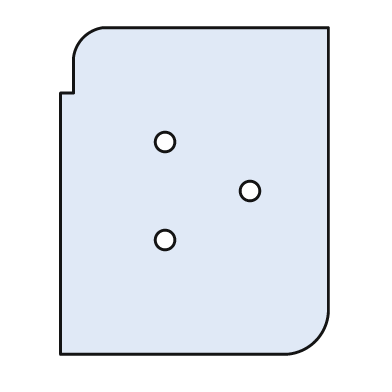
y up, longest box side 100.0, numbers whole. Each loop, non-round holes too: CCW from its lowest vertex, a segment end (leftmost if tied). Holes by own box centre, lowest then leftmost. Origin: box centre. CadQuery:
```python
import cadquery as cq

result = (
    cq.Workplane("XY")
    .moveTo(-41.0, -50.0)
    .lineTo(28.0, -50.0)
    .threePointArc((37.0, -46.0), (41.0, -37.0))
    .lineTo(41.0, 50.0)
    .lineTo(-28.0, 50.0)
    .threePointArc((-34.0, 47.0), (-37.0, 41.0))
    .lineTo(-37.0, 30.0)
    .lineTo(-41.0, 30.0)
    .close()
    .moveTo(-9.0, -15.0)
    .circle(3.0)
    .moveTo(17.0, 0.0)
    .circle(3.0)
    .moveTo(-9.0, 15.0)
    .circle(3.0)
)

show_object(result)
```